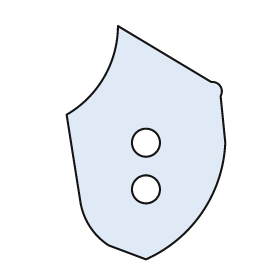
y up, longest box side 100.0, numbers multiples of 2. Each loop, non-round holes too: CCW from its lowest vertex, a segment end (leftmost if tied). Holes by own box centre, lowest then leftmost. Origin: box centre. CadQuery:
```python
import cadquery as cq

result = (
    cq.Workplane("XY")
    .moveTo(0.0, -50.0)
    .threePointArc((24.0, -30.0), (34.0, 0.0))
    .lineTo(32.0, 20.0)
    .threePointArc((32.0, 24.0), (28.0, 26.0))
    .lineTo(-12.0, 50.0)
    .threePointArc((-18.0, 28.0), (-34.0, 12.0))
    .lineTo(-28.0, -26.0)
    .threePointArc((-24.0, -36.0), (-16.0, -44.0))
    .close()
    .moveTo(0.0, -20.0)
    .circle(6.0)
    .moveTo(0.0, 0.0)
    .circle(6.0)
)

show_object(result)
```